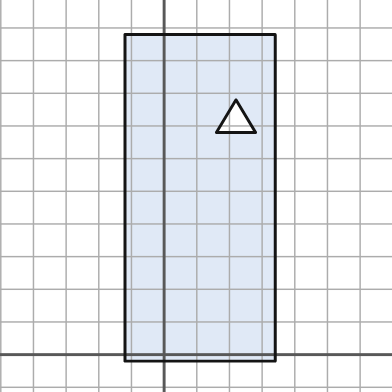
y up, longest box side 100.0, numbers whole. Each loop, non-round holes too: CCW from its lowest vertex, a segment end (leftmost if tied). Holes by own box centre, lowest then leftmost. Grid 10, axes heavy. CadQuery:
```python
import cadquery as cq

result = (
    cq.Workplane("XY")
    .moveTo(-12.0, -2.0)
    .lineTo(34.0, -2.0)
    .lineTo(34.0, 98.0)
    .lineTo(-12.0, 98.0)
    .close()
    .moveTo(16.0, 68.0)
    .lineTo(28.0, 68.0)
    .lineTo(22.0, 78.0)
    .close()
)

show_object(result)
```